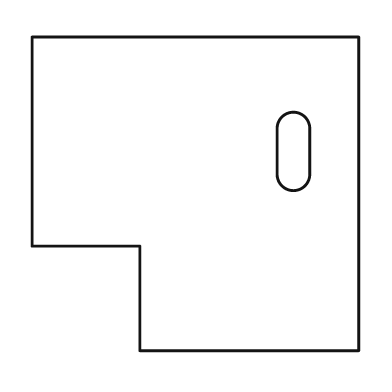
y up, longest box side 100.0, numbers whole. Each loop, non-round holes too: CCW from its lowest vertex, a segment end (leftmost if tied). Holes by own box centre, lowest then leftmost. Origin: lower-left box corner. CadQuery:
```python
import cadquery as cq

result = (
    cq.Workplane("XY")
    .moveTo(33.0, 0.0)
    .lineTo(100.0, 0.0)
    .lineTo(100.0, 96.0)
    .lineTo(0.0, 96.0)
    .lineTo(0.0, 32.0)
    .lineTo(33.0, 32.0)
    .close()
    .moveTo(75.0, 54.0)
    .threePointArc((80.0, 49.0), (85.0, 54.0))
    .lineTo(85.0, 68.0)
    .threePointArc((80.0, 73.0), (75.0, 68.0))
    .close()
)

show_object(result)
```